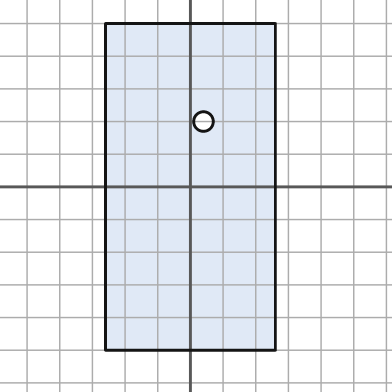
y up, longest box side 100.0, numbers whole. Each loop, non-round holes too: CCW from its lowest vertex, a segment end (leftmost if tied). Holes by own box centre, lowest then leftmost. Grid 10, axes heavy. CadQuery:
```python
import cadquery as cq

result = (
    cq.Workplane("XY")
    .moveTo(-26.0, -50.0)
    .lineTo(26.0, -50.0)
    .lineTo(26.0, 50.0)
    .lineTo(-26.0, 50.0)
    .close()
    .moveTo(4.0, 20.0)
    .circle(3.0)
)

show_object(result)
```